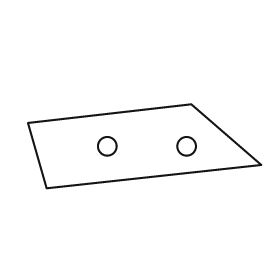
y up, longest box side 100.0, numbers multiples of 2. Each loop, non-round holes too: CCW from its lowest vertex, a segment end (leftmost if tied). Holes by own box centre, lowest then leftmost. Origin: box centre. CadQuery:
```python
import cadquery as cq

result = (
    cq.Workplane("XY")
    .moveTo(-42.0, -18.0)
    .lineTo(50.0, -8.0)
    .lineTo(20.0, 18.0)
    .lineTo(-50.0, 10.0)
    .close()
    .moveTo(-16.0, 0.0)
    .circle(4.0)
    .moveTo(18.0, 0.0)
    .circle(4.0)
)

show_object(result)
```